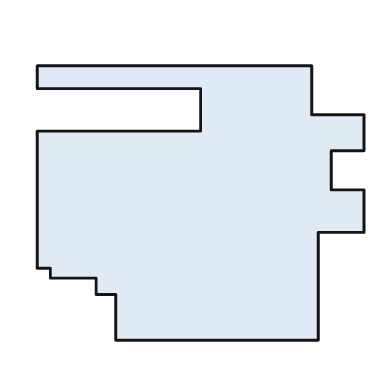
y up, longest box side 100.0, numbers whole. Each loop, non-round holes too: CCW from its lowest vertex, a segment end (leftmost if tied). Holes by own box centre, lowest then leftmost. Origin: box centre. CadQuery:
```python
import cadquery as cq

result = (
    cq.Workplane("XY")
    .moveTo(-26.0, -42.0)
    .lineTo(36.0, -42.0)
    .lineTo(36.0, -9.0)
    .lineTo(50.0, -9.0)
    .lineTo(50.0, 4.0)
    .lineTo(40.0, 4.0)
    .lineTo(40.0, 16.0)
    .lineTo(50.0, 16.0)
    .lineTo(50.0, 27.0)
    .lineTo(34.0, 27.0)
    .lineTo(34.0, 42.0)
    .lineTo(-50.0, 42.0)
    .lineTo(-50.0, 35.0)
    .lineTo(0.0, 35.0)
    .lineTo(0.0, 22.0)
    .lineTo(-50.0, 22.0)
    .lineTo(-50.0, -20.0)
    .lineTo(-46.0, -20.0)
    .lineTo(-46.0, -23.0)
    .lineTo(-32.0, -23.0)
    .lineTo(-32.0, -28.0)
    .lineTo(-26.0, -28.0)
    .close()
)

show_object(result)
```